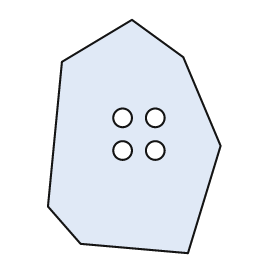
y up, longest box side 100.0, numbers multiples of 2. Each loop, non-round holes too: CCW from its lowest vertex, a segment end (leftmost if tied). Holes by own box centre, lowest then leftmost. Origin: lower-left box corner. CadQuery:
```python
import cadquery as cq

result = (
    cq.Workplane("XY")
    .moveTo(60.0, 0.0)
    .lineTo(74.0, 46.0)
    .lineTo(58.0, 84.0)
    .lineTo(36.0, 100.0)
    .lineTo(6.0, 82.0)
    .lineTo(0.0, 20.0)
    .lineTo(14.0, 4.0)
    .close()
    .moveTo(32.0, 44.0)
    .circle(4.0)
    .moveTo(46.0, 44.0)
    .circle(4.0)
    .moveTo(32.0, 58.0)
    .circle(4.0)
    .moveTo(46.0, 58.0)
    .circle(4.0)
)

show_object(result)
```